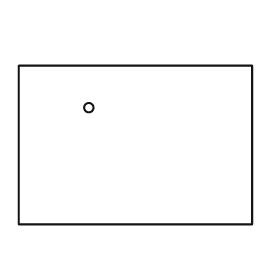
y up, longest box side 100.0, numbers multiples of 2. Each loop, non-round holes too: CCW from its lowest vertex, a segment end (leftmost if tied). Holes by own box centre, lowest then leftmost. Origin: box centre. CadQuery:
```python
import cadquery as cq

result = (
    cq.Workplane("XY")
    .moveTo(-50.0, -34.0)
    .lineTo(50.0, -34.0)
    .lineTo(50.0, 34.0)
    .lineTo(-50.0, 34.0)
    .close()
    .moveTo(-20.0, 16.0)
    .circle(2.0)
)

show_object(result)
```